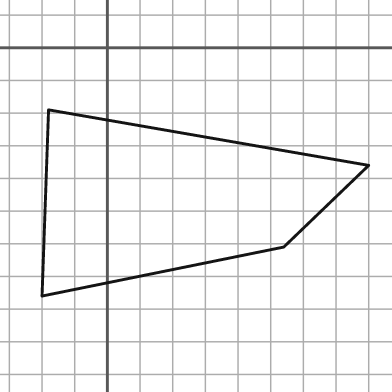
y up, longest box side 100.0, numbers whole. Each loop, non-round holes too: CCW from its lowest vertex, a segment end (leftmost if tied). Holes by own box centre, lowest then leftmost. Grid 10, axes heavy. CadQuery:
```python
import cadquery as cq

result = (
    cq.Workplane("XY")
    .moveTo(-20.0, -76.0)
    .lineTo(54.0, -61.0)
    .lineTo(80.0, -36.0)
    .lineTo(-18.0, -19.0)
    .close()
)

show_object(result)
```